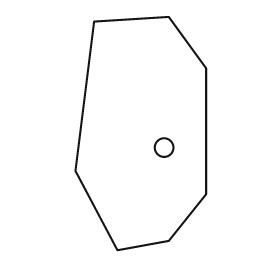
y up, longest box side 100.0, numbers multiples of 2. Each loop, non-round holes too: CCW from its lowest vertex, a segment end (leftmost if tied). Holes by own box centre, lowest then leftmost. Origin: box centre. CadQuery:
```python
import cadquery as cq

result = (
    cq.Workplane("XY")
    .moveTo(-10.0, -50.0)
    .lineTo(12.0, -46.0)
    .lineTo(28.0, -26.0)
    .lineTo(28.0, 28.0)
    .lineTo(12.0, 50.0)
    .lineTo(-20.0, 48.0)
    .lineTo(-28.0, -16.0)
    .close()
    .moveTo(10.0, -6.0)
    .circle(4.0)
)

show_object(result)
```